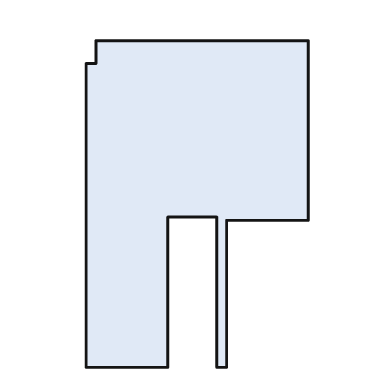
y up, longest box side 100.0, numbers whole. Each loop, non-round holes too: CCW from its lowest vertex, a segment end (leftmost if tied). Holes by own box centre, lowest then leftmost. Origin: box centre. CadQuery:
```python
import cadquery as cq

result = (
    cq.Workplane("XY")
    .moveTo(-34.0, -50.0)
    .lineTo(-9.0, -50.0)
    .lineTo(-9.0, -4.0)
    .lineTo(6.0, -4.0)
    .lineTo(6.0, -50.0)
    .lineTo(9.0, -50.0)
    .lineTo(9.0, -5.0)
    .lineTo(34.0, -5.0)
    .lineTo(34.0, 50.0)
    .lineTo(-31.0, 50.0)
    .lineTo(-31.0, 43.0)
    .lineTo(-34.0, 43.0)
    .close()
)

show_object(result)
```